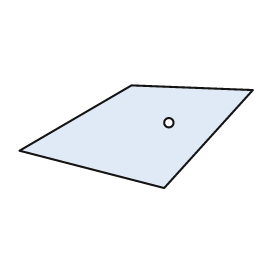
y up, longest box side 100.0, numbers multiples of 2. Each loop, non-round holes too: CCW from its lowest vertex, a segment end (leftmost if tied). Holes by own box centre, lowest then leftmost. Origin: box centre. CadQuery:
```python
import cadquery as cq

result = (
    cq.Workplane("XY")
    .moveTo(12.0, -22.0)
    .lineTo(50.0, 20.0)
    .lineTo(-2.0, 22.0)
    .lineTo(-50.0, -6.0)
    .close()
    .moveTo(14.0, 6.0)
    .circle(2.0)
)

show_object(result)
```